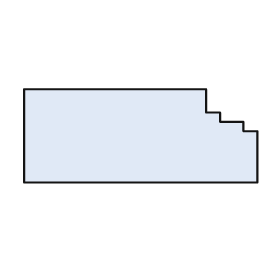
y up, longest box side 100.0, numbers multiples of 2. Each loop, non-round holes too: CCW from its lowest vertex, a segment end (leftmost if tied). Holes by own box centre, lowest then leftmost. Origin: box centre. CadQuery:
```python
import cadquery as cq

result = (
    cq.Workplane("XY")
    .moveTo(-50.0, -20.0)
    .lineTo(50.0, -20.0)
    .lineTo(50.0, 2.0)
    .lineTo(44.0, 2.0)
    .lineTo(44.0, 6.0)
    .lineTo(34.0, 6.0)
    .lineTo(34.0, 10.0)
    .lineTo(28.0, 10.0)
    .lineTo(28.0, 20.0)
    .lineTo(-50.0, 20.0)
    .close()
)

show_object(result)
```